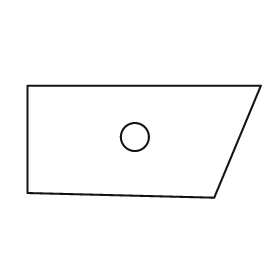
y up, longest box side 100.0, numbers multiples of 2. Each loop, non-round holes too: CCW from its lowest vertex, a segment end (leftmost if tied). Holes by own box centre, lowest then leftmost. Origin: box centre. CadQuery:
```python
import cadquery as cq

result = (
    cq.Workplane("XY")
    .moveTo(30.0, -24.0)
    .lineTo(50.0, 24.0)
    .lineTo(-50.0, 24.0)
    .lineTo(-50.0, -22.0)
    .close()
    .moveTo(-4.0, 2.0)
    .circle(6.0)
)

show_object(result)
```